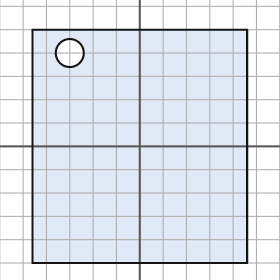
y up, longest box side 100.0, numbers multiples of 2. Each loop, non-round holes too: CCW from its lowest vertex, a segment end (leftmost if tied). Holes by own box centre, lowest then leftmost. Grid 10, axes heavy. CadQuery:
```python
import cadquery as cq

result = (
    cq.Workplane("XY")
    .moveTo(-46.0, -50.0)
    .lineTo(46.0, -50.0)
    .lineTo(46.0, 50.0)
    .lineTo(-46.0, 50.0)
    .close()
    .moveTo(-30.0, 40.0)
    .circle(6.0)
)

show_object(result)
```